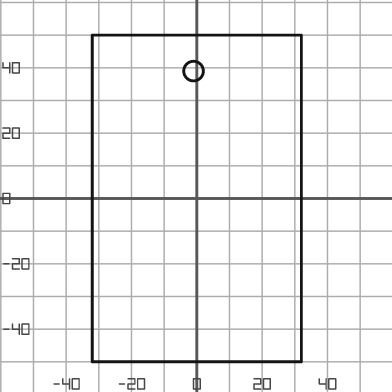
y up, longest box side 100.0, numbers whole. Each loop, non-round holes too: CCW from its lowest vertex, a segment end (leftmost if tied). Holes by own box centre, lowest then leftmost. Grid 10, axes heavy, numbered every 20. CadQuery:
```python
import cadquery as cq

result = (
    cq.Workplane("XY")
    .moveTo(-32.0, -50.0)
    .lineTo(32.0, -50.0)
    .lineTo(32.0, 50.0)
    .lineTo(-32.0, 50.0)
    .close()
    .moveTo(-1.0, 39.0)
    .circle(3.0)
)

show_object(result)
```